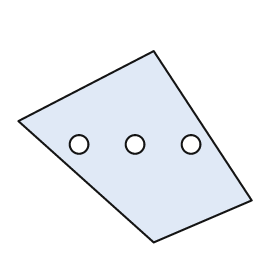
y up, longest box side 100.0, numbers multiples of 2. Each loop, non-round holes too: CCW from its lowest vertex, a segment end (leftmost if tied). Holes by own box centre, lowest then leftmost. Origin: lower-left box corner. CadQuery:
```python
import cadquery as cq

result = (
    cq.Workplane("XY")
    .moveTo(58.0, 0.0)
    .lineTo(100.0, 18.0)
    .lineTo(58.0, 82.0)
    .lineTo(0.0, 52.0)
    .close()
    .moveTo(26.0, 42.0)
    .circle(4.0)
    .moveTo(50.0, 42.0)
    .circle(4.0)
    .moveTo(74.0, 42.0)
    .circle(4.0)
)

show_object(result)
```